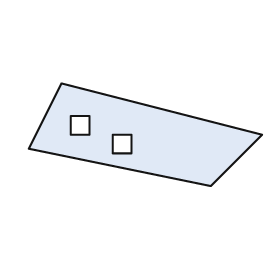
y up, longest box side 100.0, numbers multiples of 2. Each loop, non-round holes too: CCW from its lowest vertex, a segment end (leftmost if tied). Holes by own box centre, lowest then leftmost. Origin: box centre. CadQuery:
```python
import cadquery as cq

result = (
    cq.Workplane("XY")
    .moveTo(28.0, -22.0)
    .lineTo(50.0, 0.0)
    .lineTo(-36.0, 22.0)
    .lineTo(-50.0, -6.0)
    .close()
    .moveTo(-14.0, -8.0)
    .lineTo(-6.0, -8.0)
    .lineTo(-6.0, 0.0)
    .lineTo(-14.0, 0.0)
    .close()
    .moveTo(-32.0, 0.0)
    .lineTo(-24.0, 0.0)
    .lineTo(-24.0, 8.0)
    .lineTo(-32.0, 8.0)
    .close()
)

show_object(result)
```